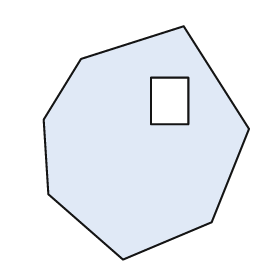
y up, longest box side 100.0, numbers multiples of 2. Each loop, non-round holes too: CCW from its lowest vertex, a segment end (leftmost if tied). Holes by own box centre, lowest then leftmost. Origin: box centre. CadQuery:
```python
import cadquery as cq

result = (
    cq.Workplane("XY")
    .moveTo(-10.0, -50.0)
    .lineTo(28.0, -34.0)
    .lineTo(44.0, 6.0)
    .lineTo(16.0, 50.0)
    .lineTo(-28.0, 36.0)
    .lineTo(-44.0, 10.0)
    .lineTo(-42.0, -22.0)
    .close()
    .moveTo(2.0, 8.0)
    .lineTo(18.0, 8.0)
    .lineTo(18.0, 28.0)
    .lineTo(2.0, 28.0)
    .close()
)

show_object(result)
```